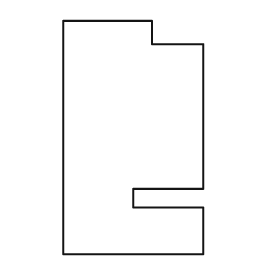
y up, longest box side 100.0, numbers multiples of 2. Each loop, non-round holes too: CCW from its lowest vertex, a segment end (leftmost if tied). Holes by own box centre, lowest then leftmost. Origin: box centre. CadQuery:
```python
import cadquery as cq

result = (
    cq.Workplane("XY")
    .moveTo(-30.0, -50.0)
    .lineTo(30.0, -50.0)
    .lineTo(30.0, -30.0)
    .lineTo(0.0, -30.0)
    .lineTo(0.0, -22.0)
    .lineTo(30.0, -22.0)
    .lineTo(30.0, 40.0)
    .lineTo(8.0, 40.0)
    .lineTo(8.0, 50.0)
    .lineTo(-30.0, 50.0)
    .close()
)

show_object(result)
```